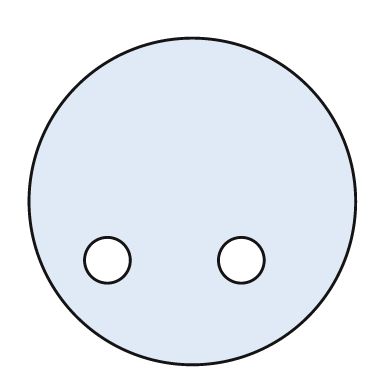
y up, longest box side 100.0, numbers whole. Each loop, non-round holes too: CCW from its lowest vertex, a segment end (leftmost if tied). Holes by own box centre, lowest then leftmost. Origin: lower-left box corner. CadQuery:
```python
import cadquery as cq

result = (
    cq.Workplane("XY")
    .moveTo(50.0, 50.0)
    .circle(50.0)
    .moveTo(24.0, 32.0)
    .circle(7.0)
    .moveTo(65.0, 32.0)
    .circle(7.0)
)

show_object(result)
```